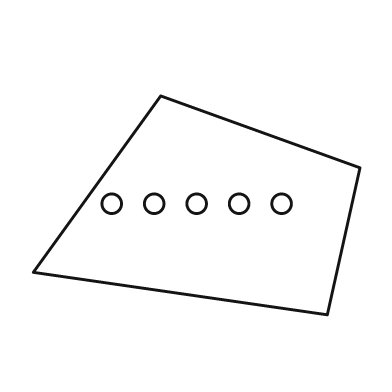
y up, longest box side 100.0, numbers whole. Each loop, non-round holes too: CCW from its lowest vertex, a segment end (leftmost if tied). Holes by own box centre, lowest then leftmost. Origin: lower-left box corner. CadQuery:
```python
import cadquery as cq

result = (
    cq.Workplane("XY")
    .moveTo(90.0, 0.0)
    .lineTo(100.0, 45.0)
    .lineTo(39.0, 67.0)
    .lineTo(0.0, 13.0)
    .close()
    .moveTo(24.0, 34.0)
    .circle(3.0)
    .moveTo(37.0, 34.0)
    .circle(3.0)
    .moveTo(50.0, 34.0)
    .circle(3.0)
    .moveTo(63.0, 34.0)
    .circle(3.0)
    .moveTo(76.0, 34.0)
    .circle(3.0)
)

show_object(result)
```